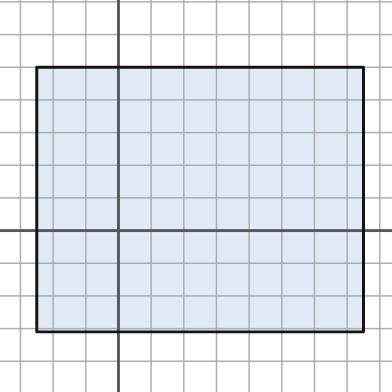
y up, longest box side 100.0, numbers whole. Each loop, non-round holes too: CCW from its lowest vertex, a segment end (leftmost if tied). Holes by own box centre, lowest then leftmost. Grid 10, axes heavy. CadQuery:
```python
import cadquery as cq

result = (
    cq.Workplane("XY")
    .moveTo(-25.0, -31.0)
    .lineTo(75.0, -31.0)
    .lineTo(75.0, 50.0)
    .lineTo(-25.0, 50.0)
    .close()
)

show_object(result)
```